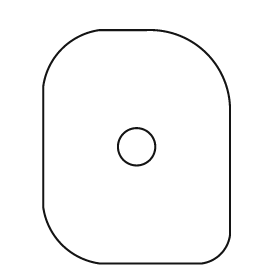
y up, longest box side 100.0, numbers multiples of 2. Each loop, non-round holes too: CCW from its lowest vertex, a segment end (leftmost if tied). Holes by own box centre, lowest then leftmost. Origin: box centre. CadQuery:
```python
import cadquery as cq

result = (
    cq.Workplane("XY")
    .moveTo(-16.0, -50.0)
    .lineTo(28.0, -50.0)
    .threePointArc((36.0, -46.0), (40.0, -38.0))
    .lineTo(40.0, 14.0)
    .threePointArc((30.0, 40.0), (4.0, 50.0))
    .lineTo(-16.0, 50.0)
    .threePointArc((-32.0, 42.0), (-40.0, 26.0))
    .lineTo(-40.0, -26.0)
    .threePointArc((-32.0, -42.0), (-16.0, -50.0))
    .close()
    .moveTo(0.0, 0.0)
    .circle(8.0)
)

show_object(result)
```